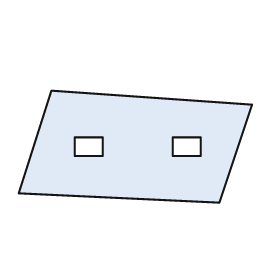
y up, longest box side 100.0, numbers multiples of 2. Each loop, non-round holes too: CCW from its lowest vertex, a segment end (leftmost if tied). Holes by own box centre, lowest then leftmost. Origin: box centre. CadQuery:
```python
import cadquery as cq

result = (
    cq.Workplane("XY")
    .moveTo(36.0, -24.0)
    .lineTo(50.0, 18.0)
    .lineTo(-36.0, 24.0)
    .lineTo(-50.0, -20.0)
    .close()
    .moveTo(-26.0, -4.0)
    .lineTo(-14.0, -4.0)
    .lineTo(-14.0, 4.0)
    .lineTo(-26.0, 4.0)
    .close()
    .moveTo(16.0, -4.0)
    .lineTo(28.0, -4.0)
    .lineTo(28.0, 4.0)
    .lineTo(16.0, 4.0)
    .close()
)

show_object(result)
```